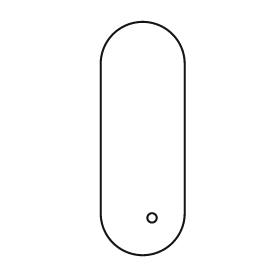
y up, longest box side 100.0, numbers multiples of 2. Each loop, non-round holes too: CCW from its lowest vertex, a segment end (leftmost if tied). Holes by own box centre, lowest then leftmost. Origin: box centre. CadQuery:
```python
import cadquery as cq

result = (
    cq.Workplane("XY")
    .moveTo(-18.0, -32.0)
    .threePointArc((0.0, -50.0), (18.0, -32.0))
    .lineTo(18.0, 32.0)
    .threePointArc((0.0, 50.0), (-18.0, 32.0))
    .close()
    .moveTo(4.0, -34.0)
    .circle(2.0)
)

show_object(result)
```